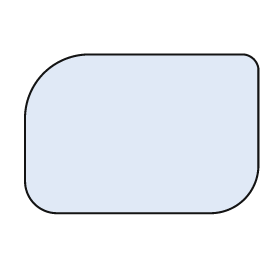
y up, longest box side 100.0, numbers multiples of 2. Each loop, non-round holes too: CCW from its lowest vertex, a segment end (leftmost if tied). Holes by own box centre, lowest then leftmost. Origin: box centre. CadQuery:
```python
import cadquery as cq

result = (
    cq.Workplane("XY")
    .moveTo(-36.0, -34.0)
    .lineTo(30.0, -34.0)
    .threePointArc((44.0, -28.0), (50.0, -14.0))
    .lineTo(50.0, 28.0)
    .threePointArc((48.0, 32.0), (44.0, 34.0))
    .lineTo(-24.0, 34.0)
    .threePointArc((-42.0, 26.0), (-50.0, 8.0))
    .lineTo(-50.0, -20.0)
    .threePointArc((-46.0, -30.0), (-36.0, -34.0))
    .close()
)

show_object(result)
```